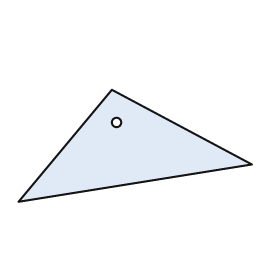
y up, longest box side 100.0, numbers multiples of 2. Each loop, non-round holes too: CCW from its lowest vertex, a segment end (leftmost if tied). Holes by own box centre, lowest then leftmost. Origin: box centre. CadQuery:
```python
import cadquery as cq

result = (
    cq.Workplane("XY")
    .moveTo(-50.0, -24.0)
    .lineTo(50.0, -8.0)
    .lineTo(-10.0, 24.0)
    .close()
    .moveTo(-8.0, 10.0)
    .circle(2.0)
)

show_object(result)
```